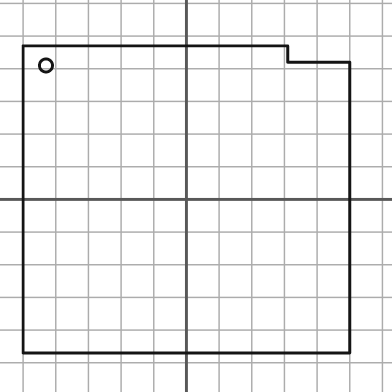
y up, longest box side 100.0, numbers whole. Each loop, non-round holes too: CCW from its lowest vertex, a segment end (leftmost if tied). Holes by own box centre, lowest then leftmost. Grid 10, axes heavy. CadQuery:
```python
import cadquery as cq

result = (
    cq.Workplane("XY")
    .moveTo(-50.0, -47.0)
    .lineTo(50.0, -47.0)
    .lineTo(50.0, 42.0)
    .lineTo(31.0, 42.0)
    .lineTo(31.0, 47.0)
    .lineTo(-50.0, 47.0)
    .close()
    .moveTo(-43.0, 41.0)
    .circle(2.0)
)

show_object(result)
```